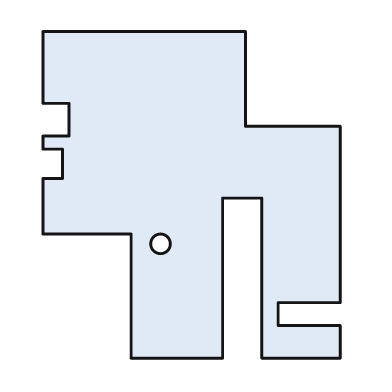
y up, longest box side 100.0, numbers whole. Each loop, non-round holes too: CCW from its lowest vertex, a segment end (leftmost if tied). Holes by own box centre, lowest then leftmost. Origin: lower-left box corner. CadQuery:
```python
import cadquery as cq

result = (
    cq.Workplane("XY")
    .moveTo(27.0, 0.0)
    .lineTo(55.0, 0.0)
    .lineTo(55.0, 49.0)
    .lineTo(67.0, 49.0)
    .lineTo(67.0, 0.0)
    .lineTo(91.0, 0.0)
    .lineTo(91.0, 10.0)
    .lineTo(72.0, 10.0)
    .lineTo(72.0, 17.0)
    .lineTo(91.0, 17.0)
    .lineTo(91.0, 71.0)
    .lineTo(62.0, 71.0)
    .lineTo(62.0, 100.0)
    .lineTo(0.0, 100.0)
    .lineTo(0.0, 78.0)
    .lineTo(8.0, 78.0)
    .lineTo(8.0, 68.0)
    .lineTo(0.0, 68.0)
    .lineTo(0.0, 64.0)
    .lineTo(6.0, 64.0)
    .lineTo(6.0, 55.0)
    .lineTo(0.0, 55.0)
    .lineTo(0.0, 38.0)
    .lineTo(27.0, 38.0)
    .close()
    .moveTo(36.0, 35.0)
    .circle(3.0)
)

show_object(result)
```